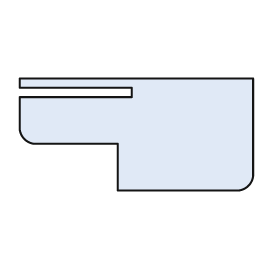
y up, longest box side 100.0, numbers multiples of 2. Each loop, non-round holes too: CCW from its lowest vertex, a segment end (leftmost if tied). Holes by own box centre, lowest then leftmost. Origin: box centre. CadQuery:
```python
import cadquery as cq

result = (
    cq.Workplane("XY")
    .moveTo(-8.0, -24.0)
    .lineTo(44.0, -24.0)
    .threePointArc((48.0, -22.0), (50.0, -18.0))
    .lineTo(50.0, 24.0)
    .lineTo(-50.0, 24.0)
    .lineTo(-50.0, 20.0)
    .lineTo(-2.0, 20.0)
    .lineTo(-2.0, 16.0)
    .lineTo(-50.0, 16.0)
    .lineTo(-50.0, 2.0)
    .threePointArc((-48.0, -2.0), (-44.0, -4.0))
    .lineTo(-8.0, -4.0)
    .close()
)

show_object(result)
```